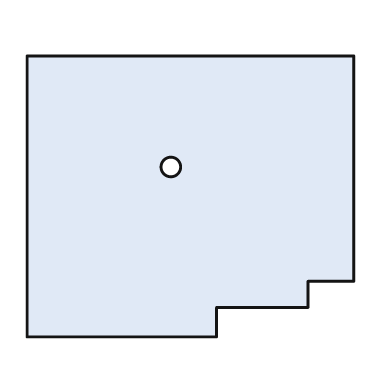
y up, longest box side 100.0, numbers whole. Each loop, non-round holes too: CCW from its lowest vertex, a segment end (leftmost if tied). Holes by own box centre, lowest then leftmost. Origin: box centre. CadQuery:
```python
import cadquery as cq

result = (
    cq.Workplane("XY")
    .moveTo(-50.0, -43.0)
    .lineTo(8.0, -43.0)
    .lineTo(8.0, -34.0)
    .lineTo(36.0, -34.0)
    .lineTo(36.0, -26.0)
    .lineTo(50.0, -26.0)
    .lineTo(50.0, 43.0)
    .lineTo(-50.0, 43.0)
    .close()
    .moveTo(-6.0, 9.0)
    .circle(3.0)
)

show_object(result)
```